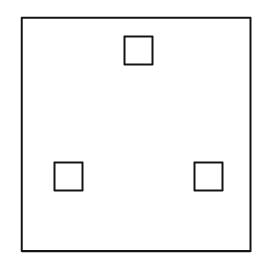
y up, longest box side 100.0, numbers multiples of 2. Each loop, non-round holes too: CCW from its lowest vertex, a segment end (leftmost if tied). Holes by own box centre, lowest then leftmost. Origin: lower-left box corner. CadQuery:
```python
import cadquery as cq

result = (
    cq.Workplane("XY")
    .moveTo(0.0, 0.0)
    .lineTo(98.0, 0.0)
    .lineTo(98.0, 100.0)
    .lineTo(0.0, 100.0)
    .close()
    .moveTo(14.0, 26.0)
    .lineTo(26.0, 26.0)
    .lineTo(26.0, 38.0)
    .lineTo(14.0, 38.0)
    .close()
    .moveTo(74.0, 26.0)
    .lineTo(86.0, 26.0)
    .lineTo(86.0, 38.0)
    .lineTo(74.0, 38.0)
    .close()
    .moveTo(44.0, 80.0)
    .lineTo(56.0, 80.0)
    .lineTo(56.0, 92.0)
    .lineTo(44.0, 92.0)
    .close()
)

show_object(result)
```